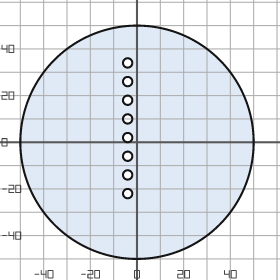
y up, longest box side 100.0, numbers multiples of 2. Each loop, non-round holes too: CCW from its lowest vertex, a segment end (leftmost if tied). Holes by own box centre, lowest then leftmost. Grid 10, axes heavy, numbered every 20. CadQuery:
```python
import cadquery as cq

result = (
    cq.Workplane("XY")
    .moveTo(0.0, 0.0)
    .circle(50.0)
    .moveTo(-4.0, -22.0)
    .circle(2.0)
    .moveTo(-4.0, -14.0)
    .circle(2.0)
    .moveTo(-4.0, -6.0)
    .circle(2.0)
    .moveTo(-4.0, 2.0)
    .circle(2.0)
    .moveTo(-4.0, 10.0)
    .circle(2.0)
    .moveTo(-4.0, 18.0)
    .circle(2.0)
    .moveTo(-4.0, 26.0)
    .circle(2.0)
    .moveTo(-4.0, 34.0)
    .circle(2.0)
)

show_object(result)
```